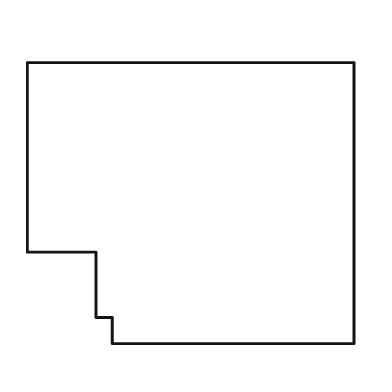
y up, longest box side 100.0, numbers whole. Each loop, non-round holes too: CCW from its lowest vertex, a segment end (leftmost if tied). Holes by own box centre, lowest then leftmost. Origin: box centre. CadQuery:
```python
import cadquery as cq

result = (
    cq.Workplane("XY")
    .moveTo(-24.0, -43.0)
    .lineTo(50.0, -43.0)
    .lineTo(50.0, 43.0)
    .lineTo(-50.0, 43.0)
    .lineTo(-50.0, -15.0)
    .lineTo(-29.0, -15.0)
    .lineTo(-29.0, -35.0)
    .lineTo(-24.0, -35.0)
    .close()
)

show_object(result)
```